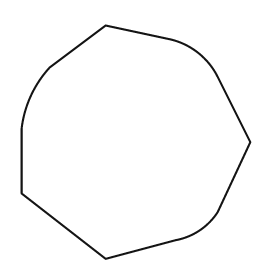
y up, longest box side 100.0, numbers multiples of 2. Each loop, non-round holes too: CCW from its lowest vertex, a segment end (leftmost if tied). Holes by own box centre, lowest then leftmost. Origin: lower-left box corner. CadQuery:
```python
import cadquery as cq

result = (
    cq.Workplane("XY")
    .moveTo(36.0, 0.0)
    .lineTo(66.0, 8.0)
    .threePointArc((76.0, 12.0), (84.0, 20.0))
    .lineTo(98.0, 50.0)
    .lineTo(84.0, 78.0)
    .threePointArc((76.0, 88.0), (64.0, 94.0))
    .lineTo(36.0, 100.0)
    .lineTo(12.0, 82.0)
    .threePointArc((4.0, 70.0), (0.0, 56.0))
    .lineTo(0.0, 28.0)
    .close()
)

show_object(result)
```